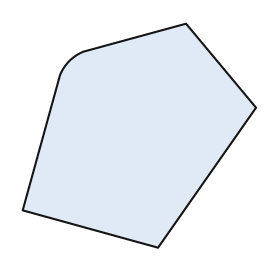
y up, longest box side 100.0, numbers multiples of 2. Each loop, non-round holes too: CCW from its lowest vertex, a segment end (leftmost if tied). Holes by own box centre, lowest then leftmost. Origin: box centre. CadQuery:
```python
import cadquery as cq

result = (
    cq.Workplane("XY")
    .moveTo(8.0, -48.0)
    .lineTo(50.0, 12.0)
    .lineTo(20.0, 48.0)
    .lineTo(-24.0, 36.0)
    .threePointArc((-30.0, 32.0), (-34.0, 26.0))
    .lineTo(-50.0, -32.0)
    .close()
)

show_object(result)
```